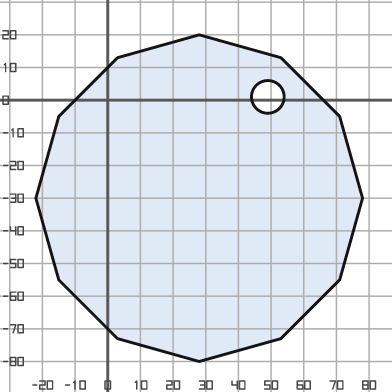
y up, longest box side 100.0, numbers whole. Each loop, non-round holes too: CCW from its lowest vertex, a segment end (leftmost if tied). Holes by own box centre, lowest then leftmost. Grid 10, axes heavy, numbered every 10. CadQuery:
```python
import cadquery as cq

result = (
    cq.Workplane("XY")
    .moveTo(28.0, -80.0)
    .lineTo(53.0, -73.0)
    .lineTo(71.0, -55.0)
    .lineTo(78.0, -30.0)
    .lineTo(71.0, -5.0)
    .lineTo(53.0, 13.0)
    .lineTo(28.0, 20.0)
    .lineTo(3.0, 13.0)
    .lineTo(-15.0, -5.0)
    .lineTo(-22.0, -30.0)
    .lineTo(-15.0, -55.0)
    .lineTo(3.0, -73.0)
    .close()
    .moveTo(49.0, 1.0)
    .circle(5.0)
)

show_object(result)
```